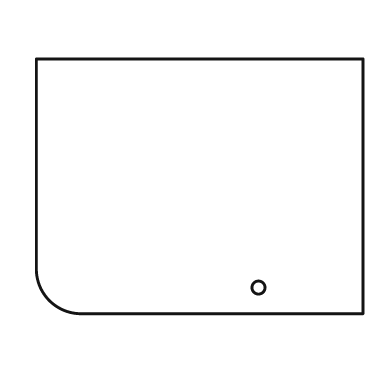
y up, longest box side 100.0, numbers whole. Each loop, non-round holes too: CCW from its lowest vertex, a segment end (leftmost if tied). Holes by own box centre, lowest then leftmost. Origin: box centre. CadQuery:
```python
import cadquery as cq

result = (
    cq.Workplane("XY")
    .moveTo(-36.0, -39.0)
    .lineTo(50.0, -39.0)
    .lineTo(50.0, 39.0)
    .lineTo(-50.0, 39.0)
    .lineTo(-50.0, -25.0)
    .threePointArc((-46.0, -35.0), (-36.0, -39.0))
    .close()
    .moveTo(18.0, -31.0)
    .circle(2.0)
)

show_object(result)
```